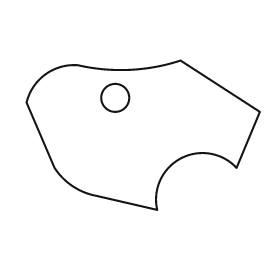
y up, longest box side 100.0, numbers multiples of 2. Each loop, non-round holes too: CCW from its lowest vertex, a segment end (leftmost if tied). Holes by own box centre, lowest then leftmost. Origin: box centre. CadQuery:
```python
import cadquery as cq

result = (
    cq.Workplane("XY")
    .moveTo(6.0, -32.0)
    .threePointArc((16.0, -10.0), (40.0, -14.0))
    .lineTo(50.0, 10.0)
    .lineTo(16.0, 32.0)
    .threePointArc((-6.0, 28.0), (-28.0, 30.0))
    .threePointArc((-42.0, 26.0), (-50.0, 14.0))
    .lineTo(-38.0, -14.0)
    .threePointArc((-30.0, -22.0), (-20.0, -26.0))
    .close()
    .moveTo(-12.0, 16.0)
    .circle(6.0)
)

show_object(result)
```